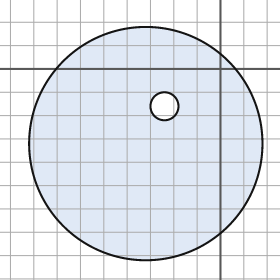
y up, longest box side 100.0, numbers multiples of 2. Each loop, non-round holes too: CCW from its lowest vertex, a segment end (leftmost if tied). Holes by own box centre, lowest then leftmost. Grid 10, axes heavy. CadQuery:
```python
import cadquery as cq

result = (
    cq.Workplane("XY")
    .moveTo(-32.0, -32.0)
    .circle(50.0)
    .moveTo(-24.0, -16.0)
    .circle(6.0)
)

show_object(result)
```